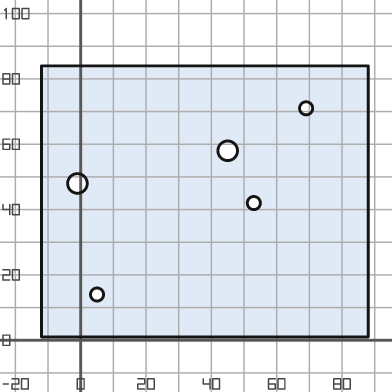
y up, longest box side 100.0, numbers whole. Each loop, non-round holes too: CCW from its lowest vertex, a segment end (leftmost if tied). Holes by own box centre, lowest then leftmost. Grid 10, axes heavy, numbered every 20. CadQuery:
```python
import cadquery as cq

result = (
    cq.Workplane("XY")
    .moveTo(-12.0, 1.0)
    .lineTo(88.0, 1.0)
    .lineTo(88.0, 84.0)
    .lineTo(-12.0, 84.0)
    .close()
    .moveTo(5.0, 14.0)
    .circle(2.0)
    .moveTo(53.0, 42.0)
    .circle(2.0)
    .moveTo(-1.0, 48.0)
    .circle(3.0)
    .moveTo(45.0, 58.0)
    .circle(3.0)
    .moveTo(69.0, 71.0)
    .circle(2.0)
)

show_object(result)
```